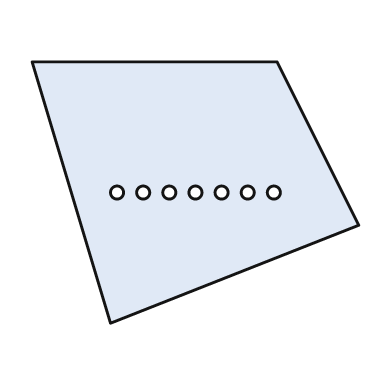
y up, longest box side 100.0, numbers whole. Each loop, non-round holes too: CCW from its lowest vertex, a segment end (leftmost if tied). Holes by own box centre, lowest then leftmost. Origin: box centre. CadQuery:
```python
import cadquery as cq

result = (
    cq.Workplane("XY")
    .moveTo(-26.0, -40.0)
    .lineTo(50.0, -10.0)
    .lineTo(25.0, 40.0)
    .lineTo(-50.0, 40.0)
    .close()
    .moveTo(-24.0, 0.0)
    .circle(2.0)
    .moveTo(-16.0, 0.0)
    .circle(2.0)
    .moveTo(-8.0, 0.0)
    .circle(2.0)
    .moveTo(0.0, 0.0)
    .circle(2.0)
    .moveTo(8.0, 0.0)
    .circle(2.0)
    .moveTo(16.0, 0.0)
    .circle(2.0)
    .moveTo(24.0, 0.0)
    .circle(2.0)
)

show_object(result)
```